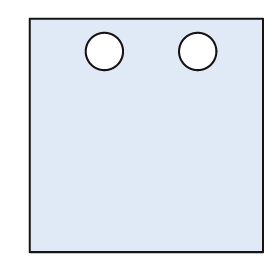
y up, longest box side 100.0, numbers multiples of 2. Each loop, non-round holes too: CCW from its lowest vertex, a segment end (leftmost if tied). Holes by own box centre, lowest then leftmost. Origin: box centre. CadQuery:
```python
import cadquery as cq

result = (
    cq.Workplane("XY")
    .moveTo(-50.0, -50.0)
    .lineTo(50.0, -50.0)
    .lineTo(50.0, 50.0)
    .lineTo(-50.0, 50.0)
    .close()
    .moveTo(-18.0, 36.0)
    .circle(8.0)
    .moveTo(22.0, 36.0)
    .circle(8.0)
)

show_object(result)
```